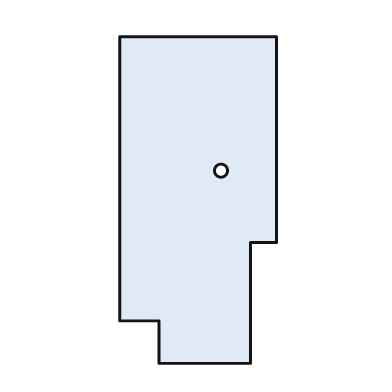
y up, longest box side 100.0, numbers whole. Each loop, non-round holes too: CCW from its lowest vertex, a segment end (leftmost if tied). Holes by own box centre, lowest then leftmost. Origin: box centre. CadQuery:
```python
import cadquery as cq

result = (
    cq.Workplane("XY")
    .moveTo(-12.0, -50.0)
    .lineTo(16.0, -50.0)
    .lineTo(16.0, -13.0)
    .lineTo(24.0, -13.0)
    .lineTo(24.0, 50.0)
    .lineTo(-24.0, 50.0)
    .lineTo(-24.0, -37.0)
    .lineTo(-12.0, -37.0)
    .close()
    .moveTo(7.0, 9.0)
    .circle(2.0)
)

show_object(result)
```